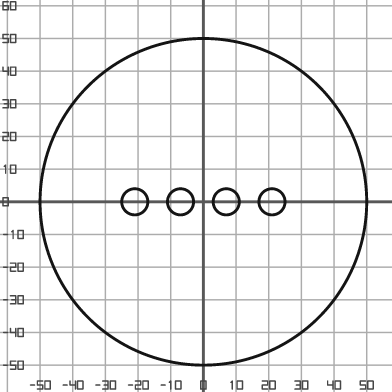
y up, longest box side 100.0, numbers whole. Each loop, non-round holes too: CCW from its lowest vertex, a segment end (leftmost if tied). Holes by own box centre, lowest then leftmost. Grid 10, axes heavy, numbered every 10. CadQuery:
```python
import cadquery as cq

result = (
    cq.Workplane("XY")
    .moveTo(0.0, 0.0)
    .circle(50.0)
    .moveTo(-21.0, 0.0)
    .circle(4.0)
    .moveTo(-7.0, 0.0)
    .circle(4.0)
    .moveTo(7.0, 0.0)
    .circle(4.0)
    .moveTo(21.0, 0.0)
    .circle(4.0)
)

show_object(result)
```